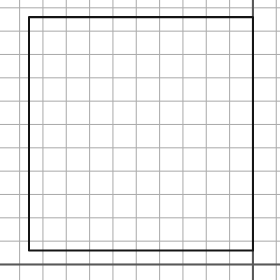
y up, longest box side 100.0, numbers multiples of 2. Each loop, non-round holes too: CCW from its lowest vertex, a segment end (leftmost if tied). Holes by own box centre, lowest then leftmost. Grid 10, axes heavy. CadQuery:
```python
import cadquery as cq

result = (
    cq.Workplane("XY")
    .moveTo(-96.0, 6.0)
    .lineTo(0.0, 6.0)
    .lineTo(0.0, 106.0)
    .lineTo(-96.0, 106.0)
    .close()
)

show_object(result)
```